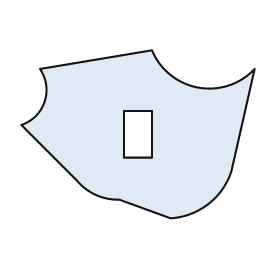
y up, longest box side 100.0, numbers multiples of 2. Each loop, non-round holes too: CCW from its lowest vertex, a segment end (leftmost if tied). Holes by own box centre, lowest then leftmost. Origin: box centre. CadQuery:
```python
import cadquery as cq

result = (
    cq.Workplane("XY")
    .moveTo(14.0, -36.0)
    .threePointArc((30.0, -30.0), (40.0, -16.0))
    .lineTo(50.0, 28.0)
    .threePointArc((26.0, 20.0), (6.0, 36.0))
    .lineTo(-42.0, 28.0)
    .threePointArc((-40.0, 14.0), (-50.0, 4.0))
    .lineTo(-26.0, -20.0)
    .threePointArc((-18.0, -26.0), (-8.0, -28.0))
    .close()
    .moveTo(-6.0, -10.0)
    .lineTo(6.0, -10.0)
    .lineTo(6.0, 10.0)
    .lineTo(-6.0, 10.0)
    .close()
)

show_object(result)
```